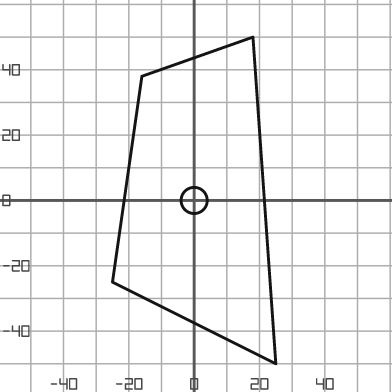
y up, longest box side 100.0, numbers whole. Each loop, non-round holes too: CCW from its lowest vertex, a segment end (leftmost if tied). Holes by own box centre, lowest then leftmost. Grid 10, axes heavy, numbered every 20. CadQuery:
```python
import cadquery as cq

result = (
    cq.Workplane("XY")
    .moveTo(25.0, -50.0)
    .lineTo(18.0, 50.0)
    .lineTo(-16.0, 38.0)
    .lineTo(-25.0, -25.0)
    .close()
    .moveTo(0.0, 0.0)
    .circle(4.0)
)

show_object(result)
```